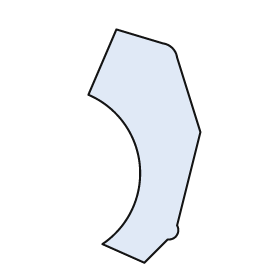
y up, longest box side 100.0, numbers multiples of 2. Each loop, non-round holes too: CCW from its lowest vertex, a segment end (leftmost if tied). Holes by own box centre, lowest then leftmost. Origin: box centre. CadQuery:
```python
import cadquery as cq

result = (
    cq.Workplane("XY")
    .moveTo(0.0, -50.0)
    .lineTo(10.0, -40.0)
    .threePointArc((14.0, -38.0), (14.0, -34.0))
    .lineTo(24.0, 6.0)
    .lineTo(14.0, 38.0)
    .threePointArc((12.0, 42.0), (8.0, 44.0))
    .lineTo(-12.0, 50.0)
    .lineTo(-24.0, 22.0)
    .threePointArc((-2.0, -8.0), (-18.0, -42.0))
    .close()
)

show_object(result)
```